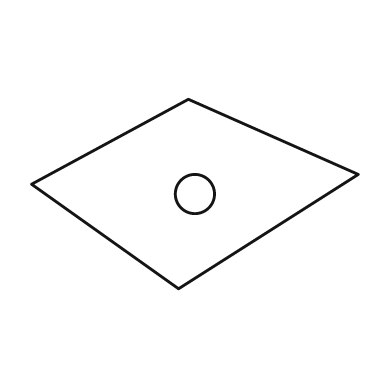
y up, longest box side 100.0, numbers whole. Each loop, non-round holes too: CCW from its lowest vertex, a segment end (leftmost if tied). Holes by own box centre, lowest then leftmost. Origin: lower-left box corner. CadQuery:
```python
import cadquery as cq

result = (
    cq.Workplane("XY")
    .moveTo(45.0, 0.0)
    .lineTo(100.0, 35.0)
    .lineTo(48.0, 58.0)
    .lineTo(0.0, 32.0)
    .close()
    .moveTo(50.0, 29.0)
    .circle(6.0)
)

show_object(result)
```